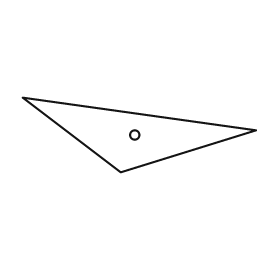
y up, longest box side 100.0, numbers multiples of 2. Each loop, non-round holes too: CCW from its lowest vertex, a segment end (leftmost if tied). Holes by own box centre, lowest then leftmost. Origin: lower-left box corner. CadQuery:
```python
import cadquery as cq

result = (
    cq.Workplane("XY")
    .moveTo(42.0, 0.0)
    .lineTo(100.0, 18.0)
    .lineTo(0.0, 32.0)
    .close()
    .moveTo(48.0, 16.0)
    .circle(2.0)
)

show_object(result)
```